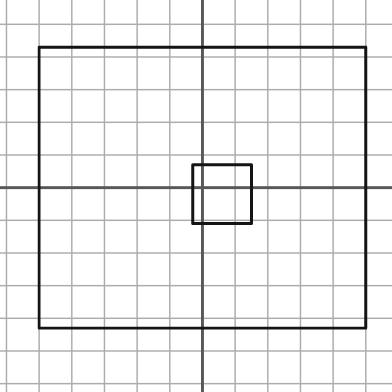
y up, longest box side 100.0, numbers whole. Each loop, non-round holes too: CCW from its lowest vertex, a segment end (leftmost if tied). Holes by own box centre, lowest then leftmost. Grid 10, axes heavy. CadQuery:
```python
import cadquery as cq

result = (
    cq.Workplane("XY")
    .moveTo(-50.0, -43.0)
    .lineTo(50.0, -43.0)
    .lineTo(50.0, 43.0)
    .lineTo(-50.0, 43.0)
    .close()
    .moveTo(-3.0, -11.0)
    .lineTo(15.0, -11.0)
    .lineTo(15.0, 7.0)
    .lineTo(-3.0, 7.0)
    .close()
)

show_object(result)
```